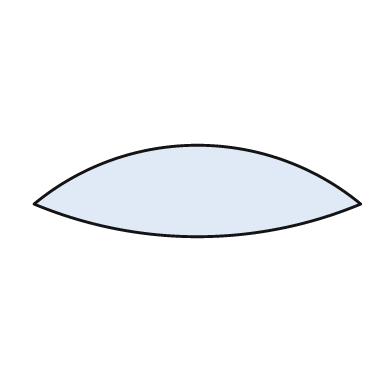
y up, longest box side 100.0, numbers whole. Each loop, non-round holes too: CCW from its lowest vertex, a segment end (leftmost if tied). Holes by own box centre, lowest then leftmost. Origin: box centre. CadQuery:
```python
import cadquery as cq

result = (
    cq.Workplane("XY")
    .moveTo(-50.0, -4.0)
    .threePointArc((0.0, -14.0), (50.0, -4.0))
    .threePointArc((0.0, 14.0), (-50.0, -4.0))
    .close()
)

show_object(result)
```